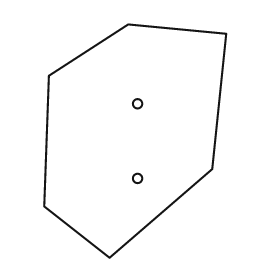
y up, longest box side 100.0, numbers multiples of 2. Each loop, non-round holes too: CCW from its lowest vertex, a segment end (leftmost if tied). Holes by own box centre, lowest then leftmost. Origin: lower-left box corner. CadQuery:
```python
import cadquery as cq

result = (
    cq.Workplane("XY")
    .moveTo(28.0, 0.0)
    .lineTo(72.0, 38.0)
    .lineTo(78.0, 96.0)
    .lineTo(36.0, 100.0)
    .lineTo(2.0, 78.0)
    .lineTo(0.0, 22.0)
    .close()
    .moveTo(40.0, 34.0)
    .circle(2.0)
    .moveTo(40.0, 66.0)
    .circle(2.0)
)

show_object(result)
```